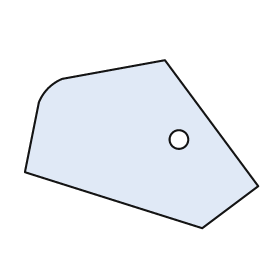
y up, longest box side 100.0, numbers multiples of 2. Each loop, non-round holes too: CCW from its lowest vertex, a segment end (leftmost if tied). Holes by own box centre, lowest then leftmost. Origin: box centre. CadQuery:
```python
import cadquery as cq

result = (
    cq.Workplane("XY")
    .moveTo(26.0, -36.0)
    .lineTo(50.0, -18.0)
    .lineTo(10.0, 36.0)
    .lineTo(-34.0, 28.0)
    .threePointArc((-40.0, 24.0), (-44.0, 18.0))
    .lineTo(-50.0, -12.0)
    .close()
    .moveTo(16.0, 2.0)
    .circle(4.0)
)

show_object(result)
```